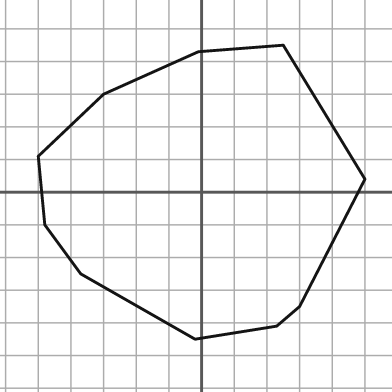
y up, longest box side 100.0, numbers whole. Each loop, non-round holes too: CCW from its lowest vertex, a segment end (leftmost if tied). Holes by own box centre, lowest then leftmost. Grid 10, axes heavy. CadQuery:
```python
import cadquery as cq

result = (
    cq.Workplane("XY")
    .moveTo(-2.0, -45.0)
    .lineTo(23.0, -41.0)
    .lineTo(30.0, -35.0)
    .lineTo(50.0, 4.0)
    .lineTo(25.0, 45.0)
    .lineTo(-1.0, 43.0)
    .lineTo(-30.0, 30.0)
    .lineTo(-50.0, 11.0)
    .lineTo(-48.0, -10.0)
    .lineTo(-37.0, -25.0)
    .close()
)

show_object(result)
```